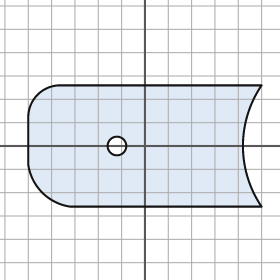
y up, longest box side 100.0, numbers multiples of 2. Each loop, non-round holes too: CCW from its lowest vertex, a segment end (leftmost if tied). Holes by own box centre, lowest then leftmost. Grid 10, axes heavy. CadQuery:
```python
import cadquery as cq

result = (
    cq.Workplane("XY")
    .moveTo(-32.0, -26.0)
    .lineTo(50.0, -26.0)
    .threePointArc((42.0, 0.0), (50.0, 26.0))
    .lineTo(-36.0, 26.0)
    .threePointArc((-46.0, 22.0), (-50.0, 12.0))
    .lineTo(-50.0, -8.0)
    .threePointArc((-44.0, -20.0), (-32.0, -26.0))
    .close()
    .moveTo(-12.0, 0.0)
    .circle(4.0)
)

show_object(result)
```